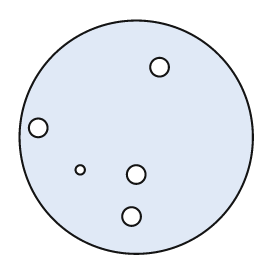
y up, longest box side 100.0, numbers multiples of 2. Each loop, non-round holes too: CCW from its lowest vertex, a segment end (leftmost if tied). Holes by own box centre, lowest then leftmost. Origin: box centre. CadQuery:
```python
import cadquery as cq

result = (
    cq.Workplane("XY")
    .moveTo(0.0, 0.0)
    .circle(50.0)
    .moveTo(-2.0, -34.0)
    .circle(4.0)
    .moveTo(0.0, -16.0)
    .circle(4.0)
    .moveTo(-24.0, -14.0)
    .circle(2.0)
    .moveTo(-42.0, 4.0)
    .circle(4.0)
    .moveTo(10.0, 30.0)
    .circle(4.0)
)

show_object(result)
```